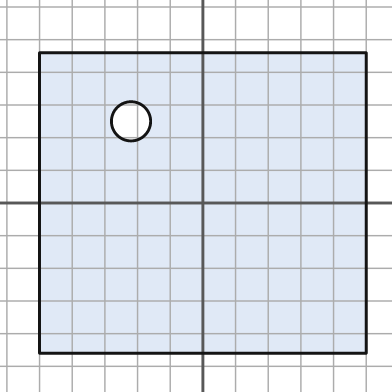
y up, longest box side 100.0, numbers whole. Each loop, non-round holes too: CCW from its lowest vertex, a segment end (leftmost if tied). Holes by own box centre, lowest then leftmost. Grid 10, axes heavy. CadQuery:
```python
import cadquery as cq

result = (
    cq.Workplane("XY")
    .moveTo(-50.0, -46.0)
    .lineTo(50.0, -46.0)
    .lineTo(50.0, 46.0)
    .lineTo(-50.0, 46.0)
    .close()
    .moveTo(-22.0, 25.0)
    .circle(6.0)
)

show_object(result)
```